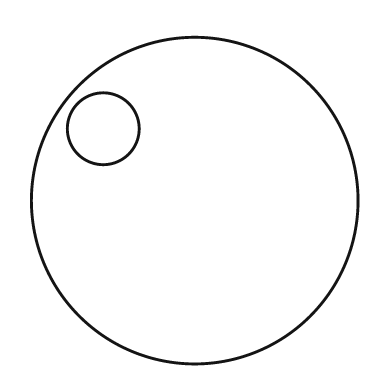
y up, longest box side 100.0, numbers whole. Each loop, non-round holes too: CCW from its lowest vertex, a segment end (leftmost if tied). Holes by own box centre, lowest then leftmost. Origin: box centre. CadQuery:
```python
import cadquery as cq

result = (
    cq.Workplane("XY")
    .moveTo(0.0, 0.0)
    .circle(50.0)
    .moveTo(-28.0, 22.0)
    .circle(11.0)
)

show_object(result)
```